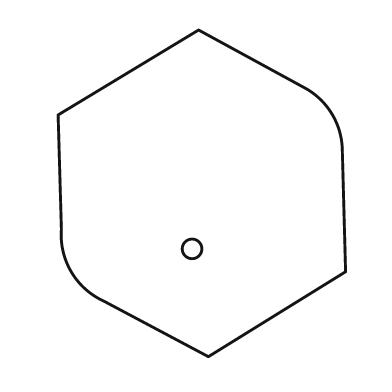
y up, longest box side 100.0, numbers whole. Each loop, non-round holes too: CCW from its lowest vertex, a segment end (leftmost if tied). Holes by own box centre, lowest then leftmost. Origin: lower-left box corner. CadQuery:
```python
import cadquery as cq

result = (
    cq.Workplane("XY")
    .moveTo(46.0, 0.0)
    .lineTo(88.0, 26.0)
    .lineTo(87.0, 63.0)
    .threePointArc((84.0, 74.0), (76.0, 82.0))
    .lineTo(43.0, 100.0)
    .lineTo(0.0, 74.0)
    .lineTo(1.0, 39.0)
    .threePointArc((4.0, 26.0), (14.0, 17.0))
    .close()
    .moveTo(41.0, 33.0)
    .circle(3.0)
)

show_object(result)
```